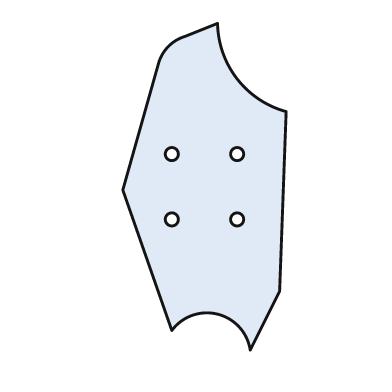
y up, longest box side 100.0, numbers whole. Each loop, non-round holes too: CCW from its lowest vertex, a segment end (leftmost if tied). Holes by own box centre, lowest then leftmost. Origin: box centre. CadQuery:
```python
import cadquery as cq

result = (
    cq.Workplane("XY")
    .moveTo(14.0, -50.0)
    .lineTo(23.0, -32.0)
    .lineTo(25.0, 23.0)
    .threePointArc((10.0, 33.0), (4.0, 50.0))
    .lineTo(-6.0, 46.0)
    .threePointArc((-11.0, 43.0), (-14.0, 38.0))
    .lineTo(-25.0, -1.0)
    .lineTo(-10.0, -44.0)
    .threePointArc((4.0, -39.0), (14.0, -50.0))
    .close()
    .moveTo(-10.0, -10.0)
    .circle(2.0)
    .moveTo(10.0, -10.0)
    .circle(2.0)
    .moveTo(-10.0, 10.0)
    .circle(2.0)
    .moveTo(10.0, 10.0)
    .circle(2.0)
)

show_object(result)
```